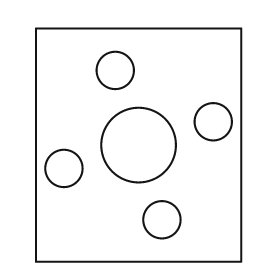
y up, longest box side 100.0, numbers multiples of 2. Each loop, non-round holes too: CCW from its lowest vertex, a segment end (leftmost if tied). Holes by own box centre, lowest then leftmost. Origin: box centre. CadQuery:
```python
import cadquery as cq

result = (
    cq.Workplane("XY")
    .moveTo(-44.0, -50.0)
    .lineTo(44.0, -50.0)
    .lineTo(44.0, 50.0)
    .lineTo(-44.0, 50.0)
    .close()
    .moveTo(10.0, -32.0)
    .circle(8.0)
    .moveTo(-32.0, -10.0)
    .circle(8.0)
    .moveTo(0.0, 0.0)
    .circle(16.0)
    .moveTo(32.0, 10.0)
    .circle(8.0)
    .moveTo(-10.0, 32.0)
    .circle(8.0)
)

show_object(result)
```